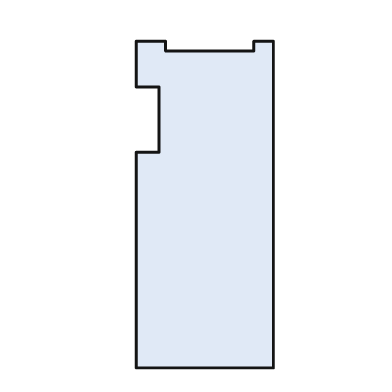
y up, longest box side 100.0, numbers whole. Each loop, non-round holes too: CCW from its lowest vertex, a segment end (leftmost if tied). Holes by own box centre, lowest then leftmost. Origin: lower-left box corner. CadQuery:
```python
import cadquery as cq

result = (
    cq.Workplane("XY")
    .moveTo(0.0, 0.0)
    .lineTo(42.0, 0.0)
    .lineTo(42.0, 100.0)
    .lineTo(36.0, 100.0)
    .lineTo(36.0, 97.0)
    .lineTo(9.0, 97.0)
    .lineTo(9.0, 100.0)
    .lineTo(0.0, 100.0)
    .lineTo(0.0, 86.0)
    .lineTo(7.0, 86.0)
    .lineTo(7.0, 66.0)
    .lineTo(0.0, 66.0)
    .close()
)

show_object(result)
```